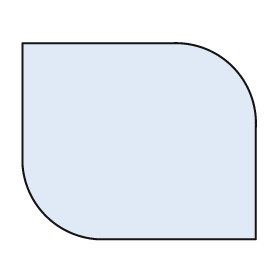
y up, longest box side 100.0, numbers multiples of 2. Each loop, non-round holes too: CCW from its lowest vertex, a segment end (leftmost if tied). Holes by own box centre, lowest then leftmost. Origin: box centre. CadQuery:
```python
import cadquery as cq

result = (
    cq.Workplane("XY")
    .moveTo(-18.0, -42.0)
    .lineTo(50.0, -42.0)
    .lineTo(50.0, 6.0)
    .threePointArc((40.0, 32.0), (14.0, 42.0))
    .lineTo(-50.0, 42.0)
    .lineTo(-50.0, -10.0)
    .threePointArc((-40.0, -32.0), (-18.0, -42.0))
    .close()
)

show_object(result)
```